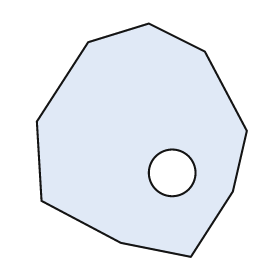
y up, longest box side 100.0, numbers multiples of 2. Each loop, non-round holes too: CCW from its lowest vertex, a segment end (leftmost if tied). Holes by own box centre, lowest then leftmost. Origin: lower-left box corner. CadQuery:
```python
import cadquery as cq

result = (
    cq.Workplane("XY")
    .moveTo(66.0, 0.0)
    .lineTo(84.0, 28.0)
    .lineTo(90.0, 54.0)
    .lineTo(72.0, 88.0)
    .lineTo(48.0, 100.0)
    .lineTo(22.0, 92.0)
    .lineTo(0.0, 58.0)
    .lineTo(2.0, 24.0)
    .lineTo(36.0, 6.0)
    .close()
    .moveTo(58.0, 36.0)
    .circle(10.0)
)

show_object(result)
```